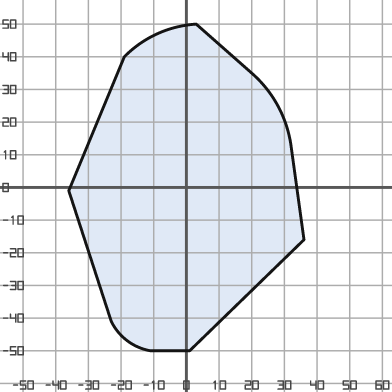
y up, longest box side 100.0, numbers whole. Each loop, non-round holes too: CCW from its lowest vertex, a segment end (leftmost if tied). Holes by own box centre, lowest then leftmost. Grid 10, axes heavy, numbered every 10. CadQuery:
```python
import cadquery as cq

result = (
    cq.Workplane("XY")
    .moveTo(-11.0, -50.0)
    .lineTo(1.0, -50.0)
    .lineTo(36.0, -16.0)
    .lineTo(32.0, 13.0)
    .threePointArc((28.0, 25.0), (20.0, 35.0))
    .lineTo(3.0, 50.0)
    .threePointArc((-9.0, 47.0), (-19.0, 40.0))
    .lineTo(-36.0, -1.0)
    .lineTo(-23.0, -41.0)
    .threePointArc((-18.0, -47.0), (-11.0, -50.0))
    .close()
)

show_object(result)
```